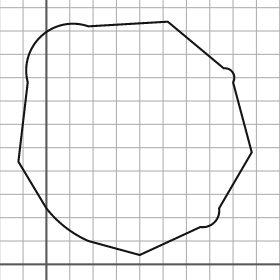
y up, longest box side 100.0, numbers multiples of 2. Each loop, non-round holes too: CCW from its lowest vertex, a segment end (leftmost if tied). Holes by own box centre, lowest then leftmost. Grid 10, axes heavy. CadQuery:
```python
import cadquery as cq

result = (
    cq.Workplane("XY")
    .moveTo(40.0, 4.0)
    .lineTo(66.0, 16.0)
    .threePointArc((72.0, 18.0), (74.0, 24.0))
    .lineTo(88.0, 48.0)
    .lineTo(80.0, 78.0)
    .threePointArc((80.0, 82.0), (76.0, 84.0))
    .lineTo(52.0, 104.0)
    .lineTo(18.0, 102.0)
    .threePointArc((-2.0, 98.0), (-8.0, 78.0))
    .lineTo(-12.0, 44.0)
    .lineTo(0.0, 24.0)
    .threePointArc((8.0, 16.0), (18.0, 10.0))
    .close()
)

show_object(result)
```